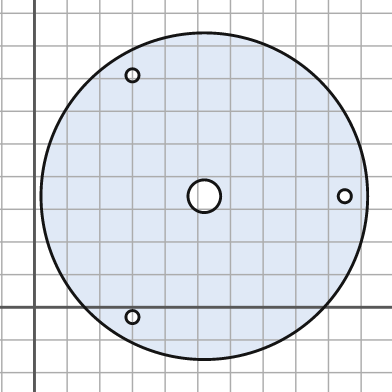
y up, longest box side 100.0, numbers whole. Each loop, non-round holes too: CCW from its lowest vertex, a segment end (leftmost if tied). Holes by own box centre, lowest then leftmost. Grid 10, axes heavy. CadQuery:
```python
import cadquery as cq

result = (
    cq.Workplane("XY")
    .moveTo(52.0, 34.0)
    .circle(50.0)
    .moveTo(30.0, -3.0)
    .circle(2.0)
    .moveTo(52.0, 34.0)
    .circle(5.0)
    .moveTo(95.0, 34.0)
    .circle(2.0)
    .moveTo(30.0, 71.0)
    .circle(2.0)
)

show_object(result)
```